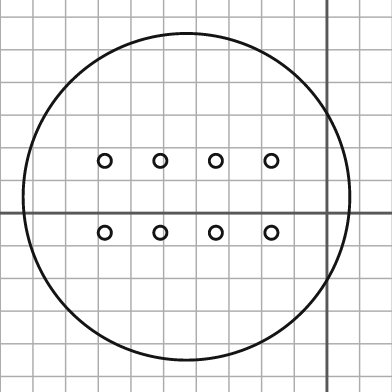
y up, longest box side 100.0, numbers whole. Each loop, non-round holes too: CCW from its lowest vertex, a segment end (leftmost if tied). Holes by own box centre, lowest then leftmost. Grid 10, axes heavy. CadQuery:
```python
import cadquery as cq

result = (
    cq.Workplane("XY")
    .moveTo(-43.0, 5.0)
    .circle(50.0)
    .moveTo(-68.0, -6.0)
    .circle(2.0)
    .moveTo(-51.0, -6.0)
    .circle(2.0)
    .moveTo(-34.0, -6.0)
    .circle(2.0)
    .moveTo(-17.0, -6.0)
    .circle(2.0)
    .moveTo(-68.0, 16.0)
    .circle(2.0)
    .moveTo(-51.0, 16.0)
    .circle(2.0)
    .moveTo(-34.0, 16.0)
    .circle(2.0)
    .moveTo(-17.0, 16.0)
    .circle(2.0)
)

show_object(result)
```